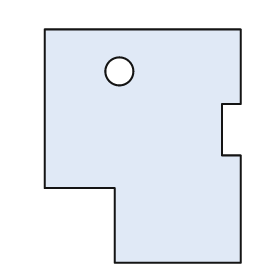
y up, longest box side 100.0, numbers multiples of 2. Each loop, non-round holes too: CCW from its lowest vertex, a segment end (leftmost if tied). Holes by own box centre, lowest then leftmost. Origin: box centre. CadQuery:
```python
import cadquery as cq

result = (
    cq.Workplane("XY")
    .moveTo(-12.0, -50.0)
    .lineTo(42.0, -50.0)
    .lineTo(42.0, -4.0)
    .lineTo(34.0, -4.0)
    .lineTo(34.0, 18.0)
    .lineTo(42.0, 18.0)
    .lineTo(42.0, 50.0)
    .lineTo(-42.0, 50.0)
    .lineTo(-42.0, -18.0)
    .lineTo(-12.0, -18.0)
    .close()
    .moveTo(-10.0, 32.0)
    .circle(6.0)
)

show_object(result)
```